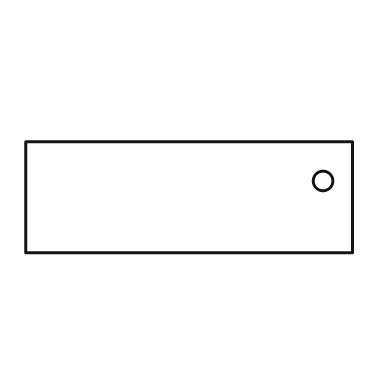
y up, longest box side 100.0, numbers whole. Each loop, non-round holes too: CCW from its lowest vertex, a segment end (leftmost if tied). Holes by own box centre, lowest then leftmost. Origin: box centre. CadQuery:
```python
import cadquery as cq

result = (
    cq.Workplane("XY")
    .moveTo(-50.0, -17.0)
    .lineTo(50.0, -17.0)
    .lineTo(50.0, 17.0)
    .lineTo(-50.0, 17.0)
    .close()
    .moveTo(41.0, 5.0)
    .circle(3.0)
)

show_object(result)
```